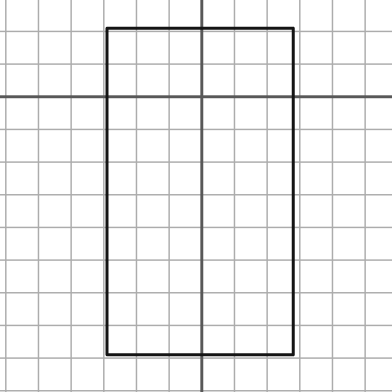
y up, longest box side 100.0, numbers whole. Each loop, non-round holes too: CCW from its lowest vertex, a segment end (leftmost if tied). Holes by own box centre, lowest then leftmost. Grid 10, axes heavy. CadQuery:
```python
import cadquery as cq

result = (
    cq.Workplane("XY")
    .moveTo(-29.0, -79.0)
    .lineTo(28.0, -79.0)
    .lineTo(28.0, 21.0)
    .lineTo(-29.0, 21.0)
    .close()
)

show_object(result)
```